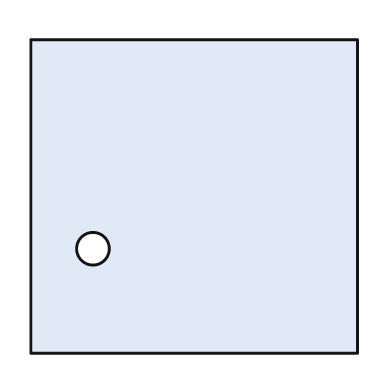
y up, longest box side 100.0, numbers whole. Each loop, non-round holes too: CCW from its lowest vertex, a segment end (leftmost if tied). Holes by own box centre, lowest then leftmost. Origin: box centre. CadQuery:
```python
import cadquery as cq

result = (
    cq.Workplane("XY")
    .moveTo(-50.0, -48.0)
    .lineTo(50.0, -48.0)
    .lineTo(50.0, 48.0)
    .lineTo(-50.0, 48.0)
    .close()
    .moveTo(-31.0, -16.0)
    .circle(5.0)
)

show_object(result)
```